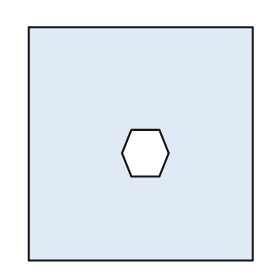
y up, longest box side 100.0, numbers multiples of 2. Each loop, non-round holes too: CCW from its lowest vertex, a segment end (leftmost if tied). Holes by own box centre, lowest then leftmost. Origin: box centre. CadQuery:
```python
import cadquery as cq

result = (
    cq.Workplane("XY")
    .moveTo(-48.0, -50.0)
    .lineTo(48.0, -50.0)
    .lineTo(48.0, 50.0)
    .lineTo(-48.0, 50.0)
    .close()
    .moveTo(-4.0, -14.0)
    .lineTo(8.0, -14.0)
    .lineTo(12.0, -4.0)
    .lineTo(8.0, 6.0)
    .lineTo(-4.0, 6.0)
    .lineTo(-8.0, -4.0)
    .close()
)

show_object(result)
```